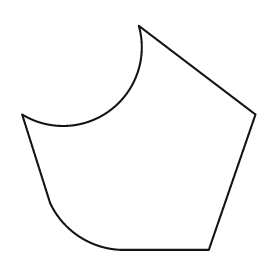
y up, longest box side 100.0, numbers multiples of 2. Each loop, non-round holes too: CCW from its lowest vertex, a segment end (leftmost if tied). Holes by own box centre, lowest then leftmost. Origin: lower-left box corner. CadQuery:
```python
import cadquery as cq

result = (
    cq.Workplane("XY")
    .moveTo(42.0, 0.0)
    .lineTo(80.0, 0.0)
    .lineTo(100.0, 58.0)
    .lineTo(50.0, 96.0)
    .threePointArc((38.0, 60.0), (0.0, 58.0))
    .lineTo(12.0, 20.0)
    .threePointArc((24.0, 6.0), (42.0, 0.0))
    .close()
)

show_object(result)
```